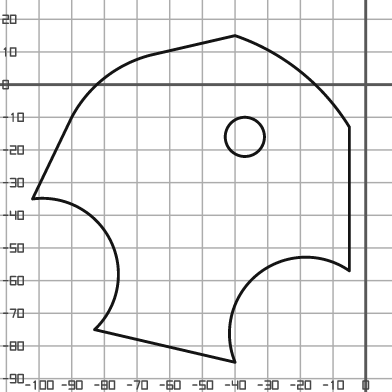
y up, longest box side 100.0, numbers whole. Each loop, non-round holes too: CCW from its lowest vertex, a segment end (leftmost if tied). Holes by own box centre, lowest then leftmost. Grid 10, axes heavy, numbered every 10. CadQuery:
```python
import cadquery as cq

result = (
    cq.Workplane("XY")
    .moveTo(-40.0, -85.0)
    .threePointArc((-33.0, -58.0), (-5.0, -57.0))
    .lineTo(-5.0, -13.0)
    .threePointArc((-20.0, 4.0), (-40.0, 15.0))
    .lineTo(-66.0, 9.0)
    .threePointArc((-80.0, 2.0), (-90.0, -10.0))
    .lineTo(-102.0, -35.0)
    .threePointArc((-78.0, -48.0), (-83.0, -75.0))
    .close()
    .moveTo(-37.0, -16.0)
    .circle(6.0)
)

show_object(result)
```